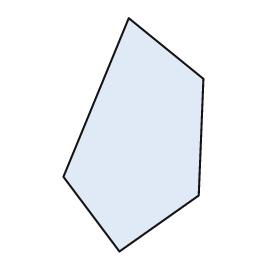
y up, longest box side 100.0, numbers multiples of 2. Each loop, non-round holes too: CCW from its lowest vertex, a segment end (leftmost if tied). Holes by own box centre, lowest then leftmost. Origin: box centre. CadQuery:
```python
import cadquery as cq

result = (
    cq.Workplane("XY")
    .moveTo(-6.0, -50.0)
    .lineTo(28.0, -26.0)
    .lineTo(30.0, 24.0)
    .lineTo(-2.0, 50.0)
    .lineTo(-30.0, -18.0)
    .close()
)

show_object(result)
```